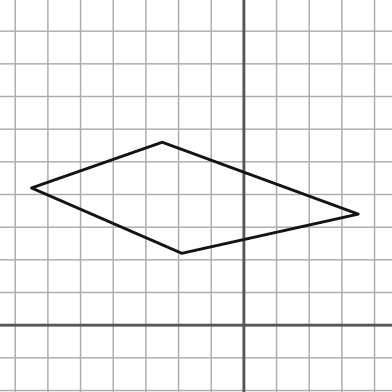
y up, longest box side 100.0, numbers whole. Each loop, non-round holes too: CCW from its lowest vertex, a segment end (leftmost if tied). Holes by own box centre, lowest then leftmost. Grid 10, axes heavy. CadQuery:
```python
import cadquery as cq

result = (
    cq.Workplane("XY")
    .moveTo(-19.0, 22.0)
    .lineTo(35.0, 34.0)
    .lineTo(-25.0, 56.0)
    .lineTo(-65.0, 42.0)
    .close()
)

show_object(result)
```